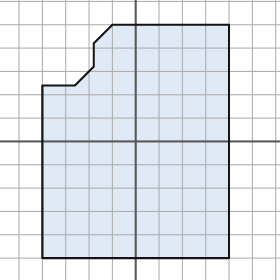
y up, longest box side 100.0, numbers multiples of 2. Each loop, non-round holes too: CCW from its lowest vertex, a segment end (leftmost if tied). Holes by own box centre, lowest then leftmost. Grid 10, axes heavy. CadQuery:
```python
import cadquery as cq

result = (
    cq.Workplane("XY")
    .moveTo(-40.0, -50.0)
    .lineTo(40.0, -50.0)
    .lineTo(40.0, 50.0)
    .lineTo(-10.0, 50.0)
    .lineTo(-18.0, 42.0)
    .lineTo(-18.0, 32.0)
    .lineTo(-26.0, 24.0)
    .lineTo(-40.0, 24.0)
    .close()
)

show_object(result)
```